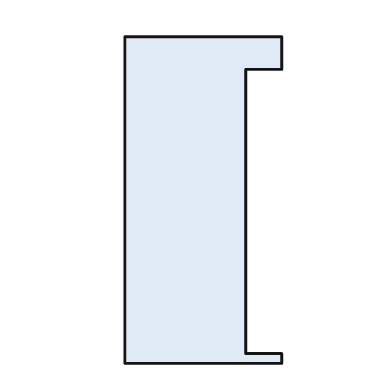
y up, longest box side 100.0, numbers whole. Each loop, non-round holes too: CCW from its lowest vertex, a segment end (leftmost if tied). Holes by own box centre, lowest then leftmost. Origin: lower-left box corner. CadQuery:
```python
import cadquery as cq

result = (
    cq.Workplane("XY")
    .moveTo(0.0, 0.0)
    .lineTo(48.0, 0.0)
    .lineTo(48.0, 3.0)
    .lineTo(37.0, 3.0)
    .lineTo(37.0, 90.0)
    .lineTo(48.0, 90.0)
    .lineTo(48.0, 100.0)
    .lineTo(0.0, 100.0)
    .close()
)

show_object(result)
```